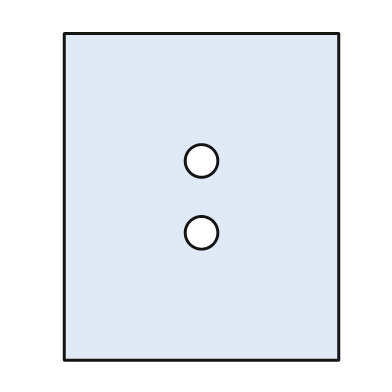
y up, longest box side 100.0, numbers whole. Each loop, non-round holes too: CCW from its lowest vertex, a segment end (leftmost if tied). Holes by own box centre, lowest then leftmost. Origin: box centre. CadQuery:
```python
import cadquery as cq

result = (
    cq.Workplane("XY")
    .moveTo(-42.0, -50.0)
    .lineTo(42.0, -50.0)
    .lineTo(42.0, 50.0)
    .lineTo(-42.0, 50.0)
    .close()
    .moveTo(0.0, -11.0)
    .circle(5.0)
    .moveTo(0.0, 11.0)
    .circle(5.0)
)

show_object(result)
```